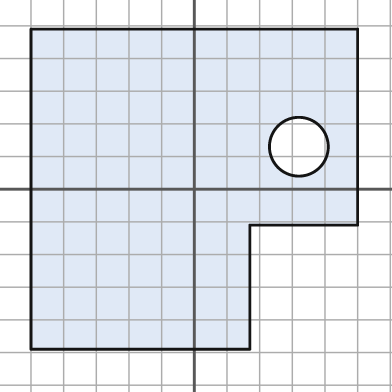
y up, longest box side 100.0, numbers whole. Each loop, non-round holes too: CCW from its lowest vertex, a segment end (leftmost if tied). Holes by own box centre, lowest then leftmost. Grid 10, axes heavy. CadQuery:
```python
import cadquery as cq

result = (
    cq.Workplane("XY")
    .moveTo(-50.0, -49.0)
    .lineTo(17.0, -49.0)
    .lineTo(17.0, -11.0)
    .lineTo(50.0, -11.0)
    .lineTo(50.0, 49.0)
    .lineTo(-50.0, 49.0)
    .close()
    .moveTo(32.0, 13.0)
    .circle(9.0)
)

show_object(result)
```